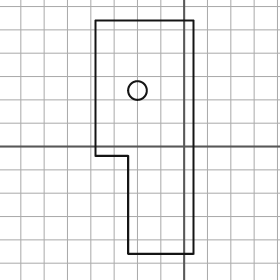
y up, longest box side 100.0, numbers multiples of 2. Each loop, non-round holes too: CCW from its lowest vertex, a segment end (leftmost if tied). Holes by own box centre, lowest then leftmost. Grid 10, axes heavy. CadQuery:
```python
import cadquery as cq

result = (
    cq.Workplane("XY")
    .moveTo(-24.0, -46.0)
    .lineTo(4.0, -46.0)
    .lineTo(4.0, 54.0)
    .lineTo(-38.0, 54.0)
    .lineTo(-38.0, -4.0)
    .lineTo(-24.0, -4.0)
    .close()
    .moveTo(-20.0, 24.0)
    .circle(4.0)
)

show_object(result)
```